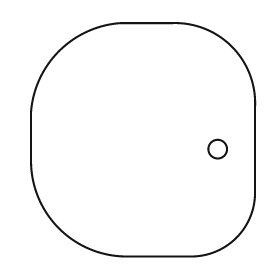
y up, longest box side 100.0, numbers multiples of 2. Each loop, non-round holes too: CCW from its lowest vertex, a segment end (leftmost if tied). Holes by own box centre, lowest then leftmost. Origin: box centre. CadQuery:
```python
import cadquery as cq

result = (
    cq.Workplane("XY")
    .moveTo(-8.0, -50.0)
    .lineTo(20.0, -50.0)
    .threePointArc((40.0, -42.0), (48.0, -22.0))
    .lineTo(48.0, 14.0)
    .threePointArc((38.0, 40.0), (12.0, 50.0))
    .lineTo(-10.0, 50.0)
    .threePointArc((-36.0, 38.0), (-48.0, 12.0))
    .lineTo(-48.0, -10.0)
    .threePointArc((-36.0, -38.0), (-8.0, -50.0))
    .close()
    .moveTo(32.0, -4.0)
    .circle(4.0)
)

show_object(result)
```